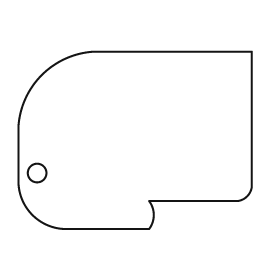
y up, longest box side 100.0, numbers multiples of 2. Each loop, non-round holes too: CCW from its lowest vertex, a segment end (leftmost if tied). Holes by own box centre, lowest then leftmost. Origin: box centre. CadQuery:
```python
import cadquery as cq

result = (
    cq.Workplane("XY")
    .moveTo(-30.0, -38.0)
    .lineTo(6.0, -38.0)
    .threePointArc((8.0, -32.0), (6.0, -26.0))
    .lineTo(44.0, -26.0)
    .threePointArc((48.0, -24.0), (50.0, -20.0))
    .lineTo(50.0, 38.0)
    .lineTo(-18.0, 38.0)
    .threePointArc((-40.0, 28.0), (-50.0, 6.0))
    .lineTo(-50.0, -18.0)
    .threePointArc((-44.0, -32.0), (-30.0, -38.0))
    .close()
    .moveTo(-42.0, -14.0)
    .circle(4.0)
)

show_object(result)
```